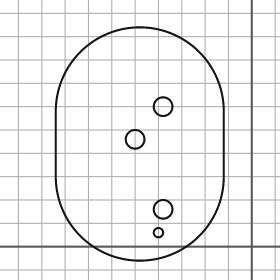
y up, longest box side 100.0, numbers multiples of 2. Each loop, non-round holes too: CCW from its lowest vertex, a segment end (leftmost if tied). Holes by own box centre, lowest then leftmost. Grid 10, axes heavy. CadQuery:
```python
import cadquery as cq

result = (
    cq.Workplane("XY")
    .moveTo(-84.0, 30.0)
    .threePointArc((-48.0, -6.0), (-12.0, 30.0))
    .lineTo(-12.0, 58.0)
    .threePointArc((-48.0, 94.0), (-84.0, 58.0))
    .close()
    .moveTo(-40.0, 6.0)
    .circle(2.0)
    .moveTo(-38.0, 16.0)
    .circle(4.0)
    .moveTo(-50.0, 46.0)
    .circle(4.0)
    .moveTo(-38.0, 60.0)
    .circle(4.0)
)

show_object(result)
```